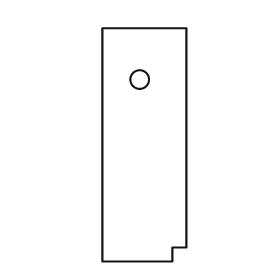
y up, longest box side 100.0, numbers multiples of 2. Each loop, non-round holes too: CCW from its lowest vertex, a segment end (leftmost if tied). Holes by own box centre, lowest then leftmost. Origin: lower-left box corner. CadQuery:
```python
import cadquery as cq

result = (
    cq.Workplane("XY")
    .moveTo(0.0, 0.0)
    .lineTo(30.0, 0.0)
    .lineTo(30.0, 6.0)
    .lineTo(36.0, 6.0)
    .lineTo(36.0, 100.0)
    .lineTo(0.0, 100.0)
    .close()
    .moveTo(16.0, 78.0)
    .circle(4.0)
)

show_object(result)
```